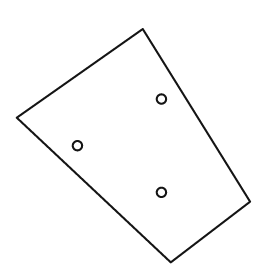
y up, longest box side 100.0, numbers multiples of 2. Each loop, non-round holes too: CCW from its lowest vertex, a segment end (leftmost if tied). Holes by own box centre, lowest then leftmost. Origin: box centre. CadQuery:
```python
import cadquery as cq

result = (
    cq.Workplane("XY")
    .moveTo(16.0, -50.0)
    .lineTo(50.0, -24.0)
    .lineTo(4.0, 50.0)
    .lineTo(-50.0, 12.0)
    .close()
    .moveTo(12.0, -20.0)
    .circle(2.0)
    .moveTo(-24.0, 0.0)
    .circle(2.0)
    .moveTo(12.0, 20.0)
    .circle(2.0)
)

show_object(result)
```